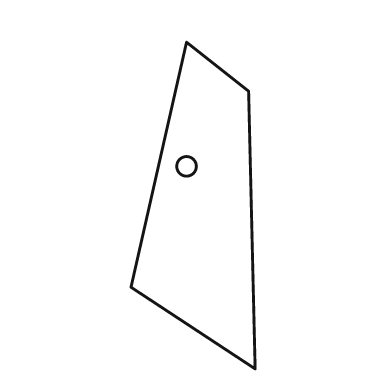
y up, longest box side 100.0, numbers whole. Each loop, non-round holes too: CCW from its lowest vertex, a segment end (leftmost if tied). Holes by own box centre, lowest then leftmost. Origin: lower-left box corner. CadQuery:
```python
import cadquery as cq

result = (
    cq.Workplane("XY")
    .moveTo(38.0, 0.0)
    .lineTo(36.0, 85.0)
    .lineTo(17.0, 100.0)
    .lineTo(0.0, 25.0)
    .close()
    .moveTo(17.0, 62.0)
    .circle(3.0)
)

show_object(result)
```